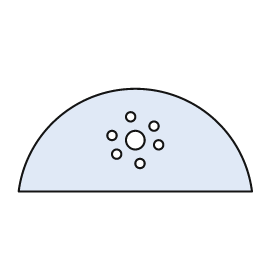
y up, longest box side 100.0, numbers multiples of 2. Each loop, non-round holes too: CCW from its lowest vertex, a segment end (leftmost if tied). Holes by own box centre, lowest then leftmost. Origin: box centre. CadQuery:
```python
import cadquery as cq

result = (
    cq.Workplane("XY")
    .moveTo(-50.0, -22.0)
    .lineTo(50.0, -22.0)
    .threePointArc((0.0, 22.0), (-50.0, -22.0))
    .close()
    .moveTo(2.0, -10.0)
    .circle(2.0)
    .moveTo(-8.0, -6.0)
    .circle(2.0)
    .moveTo(10.0, -2.0)
    .circle(2.0)
    .moveTo(0.0, 0.0)
    .circle(4.0)
    .moveTo(-10.0, 2.0)
    .circle(2.0)
    .moveTo(8.0, 6.0)
    .circle(2.0)
    .moveTo(-2.0, 10.0)
    .circle(2.0)
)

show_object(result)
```